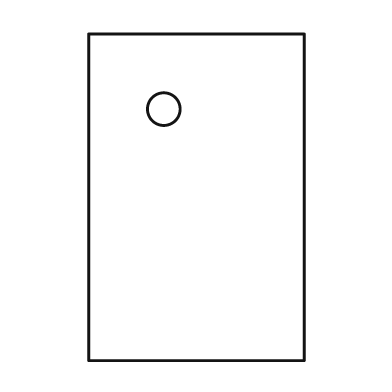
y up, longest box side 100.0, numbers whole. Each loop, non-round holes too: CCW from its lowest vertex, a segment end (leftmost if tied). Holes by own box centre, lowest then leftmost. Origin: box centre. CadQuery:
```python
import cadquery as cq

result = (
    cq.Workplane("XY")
    .moveTo(-33.0, -50.0)
    .lineTo(33.0, -50.0)
    .lineTo(33.0, 50.0)
    .lineTo(-33.0, 50.0)
    .close()
    .moveTo(-10.0, 27.0)
    .circle(5.0)
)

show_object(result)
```